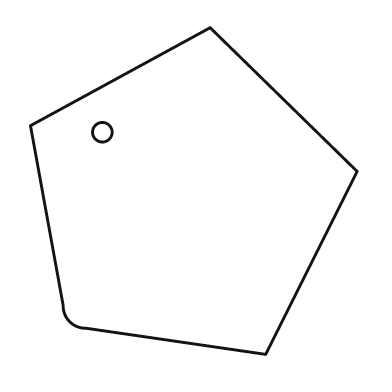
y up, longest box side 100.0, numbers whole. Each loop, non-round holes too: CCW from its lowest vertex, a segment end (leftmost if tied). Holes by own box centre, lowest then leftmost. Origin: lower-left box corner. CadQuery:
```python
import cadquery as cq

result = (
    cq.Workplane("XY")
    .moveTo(72.0, 0.0)
    .lineTo(100.0, 56.0)
    .lineTo(55.0, 100.0)
    .lineTo(0.0, 70.0)
    .lineTo(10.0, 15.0)
    .threePointArc((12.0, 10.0), (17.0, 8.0))
    .close()
    .moveTo(22.0, 68.0)
    .circle(3.0)
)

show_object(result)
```